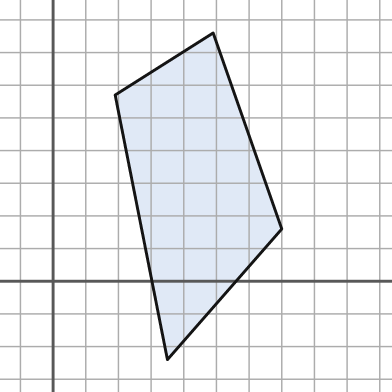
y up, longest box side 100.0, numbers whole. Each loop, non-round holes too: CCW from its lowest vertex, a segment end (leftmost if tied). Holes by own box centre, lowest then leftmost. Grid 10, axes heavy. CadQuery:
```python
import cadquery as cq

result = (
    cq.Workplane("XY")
    .moveTo(35.0, -24.0)
    .lineTo(70.0, 16.0)
    .lineTo(49.0, 76.0)
    .lineTo(19.0, 57.0)
    .close()
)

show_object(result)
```